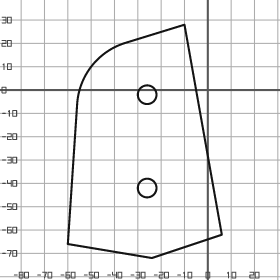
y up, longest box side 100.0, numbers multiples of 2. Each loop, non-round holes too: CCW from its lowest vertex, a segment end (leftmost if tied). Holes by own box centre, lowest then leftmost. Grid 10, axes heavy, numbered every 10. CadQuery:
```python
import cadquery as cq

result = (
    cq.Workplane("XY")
    .moveTo(-24.0, -72.0)
    .lineTo(6.0, -62.0)
    .lineTo(-10.0, 28.0)
    .lineTo(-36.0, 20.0)
    .threePointArc((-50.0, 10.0), (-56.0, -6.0))
    .lineTo(-60.0, -66.0)
    .close()
    .moveTo(-26.0, -42.0)
    .circle(4.0)
    .moveTo(-26.0, -2.0)
    .circle(4.0)
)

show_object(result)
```